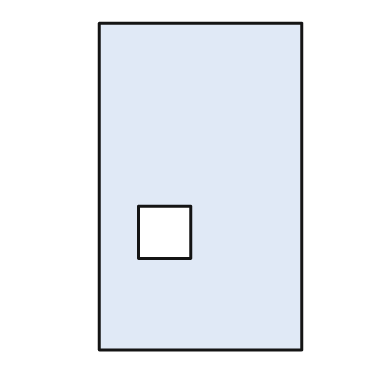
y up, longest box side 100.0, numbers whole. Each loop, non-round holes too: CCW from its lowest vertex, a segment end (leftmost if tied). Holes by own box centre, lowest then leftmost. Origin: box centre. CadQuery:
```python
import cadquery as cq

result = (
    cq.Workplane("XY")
    .moveTo(-31.0, -50.0)
    .lineTo(31.0, -50.0)
    .lineTo(31.0, 50.0)
    .lineTo(-31.0, 50.0)
    .close()
    .moveTo(-19.0, -22.0)
    .lineTo(-3.0, -22.0)
    .lineTo(-3.0, -6.0)
    .lineTo(-19.0, -6.0)
    .close()
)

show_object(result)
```